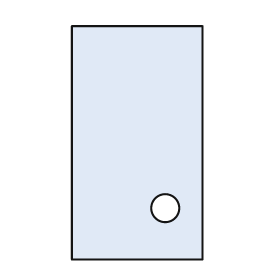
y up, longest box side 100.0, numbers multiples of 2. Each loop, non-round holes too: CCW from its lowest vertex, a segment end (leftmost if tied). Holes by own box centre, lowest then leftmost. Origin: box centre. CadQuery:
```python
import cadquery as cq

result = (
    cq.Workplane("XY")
    .moveTo(-28.0, -50.0)
    .lineTo(28.0, -50.0)
    .lineTo(28.0, 50.0)
    .lineTo(-28.0, 50.0)
    .close()
    .moveTo(12.0, -28.0)
    .circle(6.0)
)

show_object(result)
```